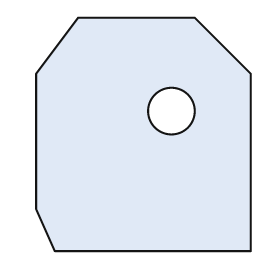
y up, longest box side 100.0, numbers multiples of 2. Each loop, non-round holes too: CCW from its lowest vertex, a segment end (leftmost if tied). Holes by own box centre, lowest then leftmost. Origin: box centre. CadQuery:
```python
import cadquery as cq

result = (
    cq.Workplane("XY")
    .moveTo(-38.0, -50.0)
    .lineTo(46.0, -50.0)
    .lineTo(46.0, 26.0)
    .lineTo(22.0, 50.0)
    .lineTo(-28.0, 50.0)
    .lineTo(-46.0, 26.0)
    .lineTo(-46.0, -32.0)
    .close()
    .moveTo(12.0, 10.0)
    .circle(10.0)
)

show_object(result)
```